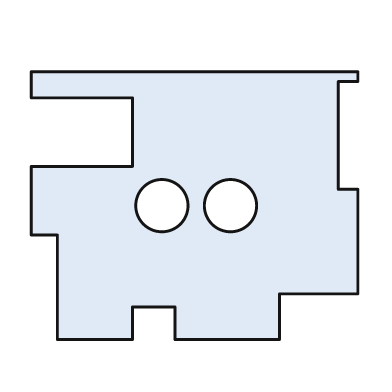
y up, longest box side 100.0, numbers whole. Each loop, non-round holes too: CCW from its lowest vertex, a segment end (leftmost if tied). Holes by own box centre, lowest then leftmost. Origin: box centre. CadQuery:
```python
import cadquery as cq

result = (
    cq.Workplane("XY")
    .moveTo(-42.0, -41.0)
    .lineTo(-19.0, -41.0)
    .lineTo(-19.0, -31.0)
    .lineTo(-6.0, -31.0)
    .lineTo(-6.0, -41.0)
    .lineTo(26.0, -41.0)
    .lineTo(26.0, -27.0)
    .lineTo(50.0, -27.0)
    .lineTo(50.0, 5.0)
    .lineTo(44.0, 5.0)
    .lineTo(44.0, 38.0)
    .lineTo(50.0, 38.0)
    .lineTo(50.0, 41.0)
    .lineTo(-50.0, 41.0)
    .lineTo(-50.0, 33.0)
    .lineTo(-19.0, 33.0)
    .lineTo(-19.0, 12.0)
    .lineTo(-50.0, 12.0)
    .lineTo(-50.0, -9.0)
    .lineTo(-42.0, -9.0)
    .close()
    .moveTo(-10.0, 0.0)
    .circle(8.0)
    .moveTo(11.0, 0.0)
    .circle(8.0)
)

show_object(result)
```